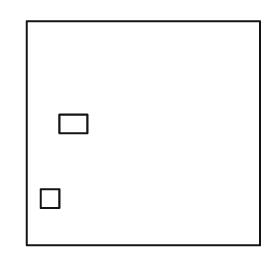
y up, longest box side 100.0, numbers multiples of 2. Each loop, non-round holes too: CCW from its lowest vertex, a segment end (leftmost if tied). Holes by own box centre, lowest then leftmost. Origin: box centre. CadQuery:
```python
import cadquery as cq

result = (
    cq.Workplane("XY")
    .moveTo(-50.0, -48.0)
    .lineTo(50.0, -48.0)
    .lineTo(50.0, 48.0)
    .lineTo(-50.0, 48.0)
    .close()
    .moveTo(-44.0, -32.0)
    .lineTo(-36.0, -32.0)
    .lineTo(-36.0, -24.0)
    .lineTo(-44.0, -24.0)
    .close()
    .moveTo(-36.0, 0.0)
    .lineTo(-24.0, 0.0)
    .lineTo(-24.0, 8.0)
    .lineTo(-36.0, 8.0)
    .close()
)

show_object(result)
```